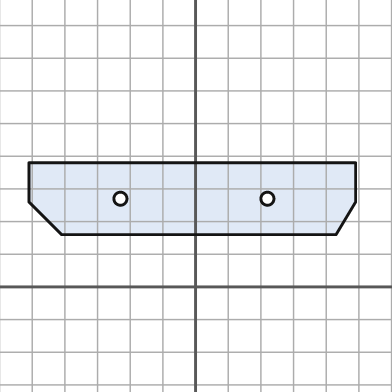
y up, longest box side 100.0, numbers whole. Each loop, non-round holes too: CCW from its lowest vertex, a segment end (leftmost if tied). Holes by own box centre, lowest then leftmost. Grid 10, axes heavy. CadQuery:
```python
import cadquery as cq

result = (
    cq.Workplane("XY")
    .moveTo(-41.0, 16.0)
    .lineTo(43.0, 16.0)
    .lineTo(49.0, 26.0)
    .lineTo(49.0, 38.0)
    .lineTo(-51.0, 38.0)
    .lineTo(-51.0, 26.0)
    .close()
    .moveTo(-23.0, 27.0)
    .circle(2.0)
    .moveTo(22.0, 27.0)
    .circle(2.0)
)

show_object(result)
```